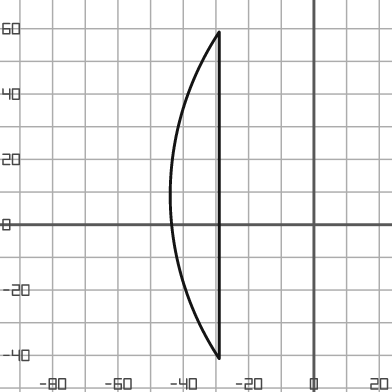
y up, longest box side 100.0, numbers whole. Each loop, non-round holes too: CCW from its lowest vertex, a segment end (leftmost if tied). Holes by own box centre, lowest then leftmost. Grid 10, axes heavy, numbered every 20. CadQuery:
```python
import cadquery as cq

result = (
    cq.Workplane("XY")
    .moveTo(-29.0, -41.0)
    .lineTo(-29.0, 59.0)
    .threePointArc((-44.0, 9.0), (-29.0, -41.0))
    .close()
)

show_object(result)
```